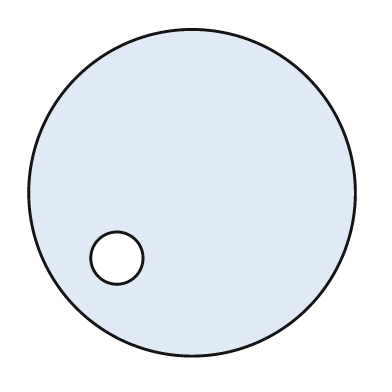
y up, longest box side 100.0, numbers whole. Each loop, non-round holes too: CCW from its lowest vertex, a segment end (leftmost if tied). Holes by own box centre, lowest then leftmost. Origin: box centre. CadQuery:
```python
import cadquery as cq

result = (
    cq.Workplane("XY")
    .moveTo(0.0, 0.0)
    .circle(50.0)
    .moveTo(-23.0, -20.0)
    .circle(8.0)
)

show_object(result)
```